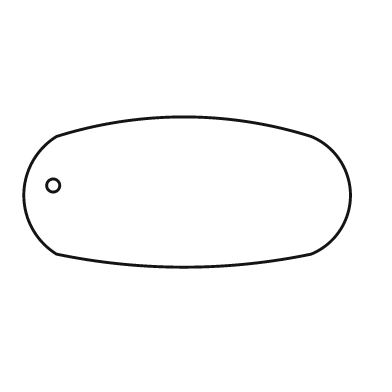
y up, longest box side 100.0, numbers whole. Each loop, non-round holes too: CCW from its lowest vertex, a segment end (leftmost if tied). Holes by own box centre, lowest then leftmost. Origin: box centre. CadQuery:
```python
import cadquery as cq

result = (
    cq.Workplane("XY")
    .moveTo(-40.0, -19.0)
    .threePointArc((-1.0, -23.0), (38.0, -19.0))
    .threePointArc((50.0, -1.0), (38.0, 17.0))
    .threePointArc((-1.0, 23.0), (-40.0, 17.0))
    .threePointArc((-50.0, -1.0), (-40.0, -19.0))
    .close()
    .moveTo(-41.0, 2.0)
    .circle(2.0)
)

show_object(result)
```